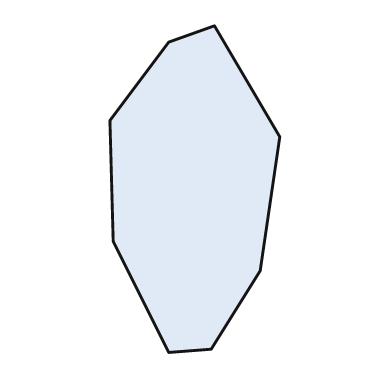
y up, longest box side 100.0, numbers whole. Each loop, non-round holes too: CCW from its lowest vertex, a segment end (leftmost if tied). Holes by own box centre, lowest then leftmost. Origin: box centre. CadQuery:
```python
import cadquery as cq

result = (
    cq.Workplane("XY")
    .moveTo(-8.0, -50.0)
    .lineTo(5.0, -49.0)
    .lineTo(20.0, -25.0)
    .lineTo(26.0, 16.0)
    .lineTo(6.0, 50.0)
    .lineTo(-8.0, 45.0)
    .lineTo(-26.0, 21.0)
    .lineTo(-25.0, -16.0)
    .close()
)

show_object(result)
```